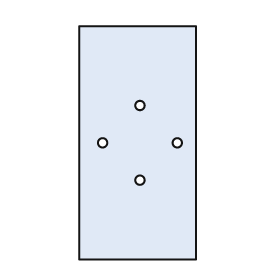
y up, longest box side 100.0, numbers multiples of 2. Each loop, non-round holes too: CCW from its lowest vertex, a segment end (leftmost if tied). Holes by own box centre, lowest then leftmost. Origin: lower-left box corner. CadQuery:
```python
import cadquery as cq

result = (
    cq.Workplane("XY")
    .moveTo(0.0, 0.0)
    .lineTo(50.0, 0.0)
    .lineTo(50.0, 100.0)
    .lineTo(0.0, 100.0)
    .close()
    .moveTo(26.0, 34.0)
    .circle(2.0)
    .moveTo(10.0, 50.0)
    .circle(2.0)
    .moveTo(42.0, 50.0)
    .circle(2.0)
    .moveTo(26.0, 66.0)
    .circle(2.0)
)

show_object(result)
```